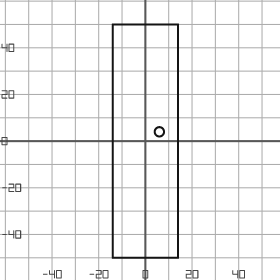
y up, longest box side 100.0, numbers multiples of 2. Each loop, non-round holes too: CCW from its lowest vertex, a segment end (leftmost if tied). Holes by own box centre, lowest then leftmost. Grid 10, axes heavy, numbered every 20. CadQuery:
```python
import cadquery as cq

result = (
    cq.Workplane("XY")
    .moveTo(-14.0, -50.0)
    .lineTo(14.0, -50.0)
    .lineTo(14.0, 50.0)
    .lineTo(-14.0, 50.0)
    .close()
    .moveTo(6.0, 4.0)
    .circle(2.0)
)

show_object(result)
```